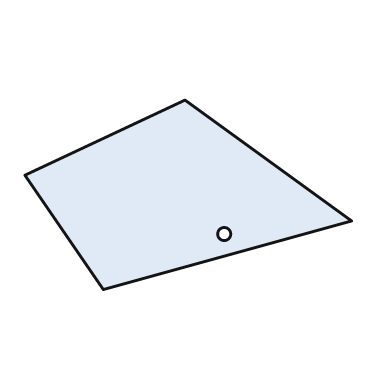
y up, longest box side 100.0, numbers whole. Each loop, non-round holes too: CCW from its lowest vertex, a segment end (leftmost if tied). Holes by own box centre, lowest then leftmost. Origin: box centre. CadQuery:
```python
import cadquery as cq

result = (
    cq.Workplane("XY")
    .moveTo(-26.0, -29.0)
    .lineTo(50.0, -8.0)
    .lineTo(-1.0, 29.0)
    .lineTo(-50.0, 6.0)
    .close()
    .moveTo(11.0, -12.0)
    .circle(2.0)
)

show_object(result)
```